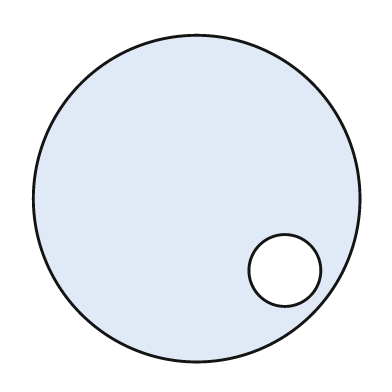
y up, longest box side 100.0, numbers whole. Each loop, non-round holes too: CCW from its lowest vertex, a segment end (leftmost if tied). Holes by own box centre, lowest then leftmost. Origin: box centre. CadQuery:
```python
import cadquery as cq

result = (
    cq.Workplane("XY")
    .moveTo(0.0, 0.0)
    .circle(50.0)
    .moveTo(27.0, -22.0)
    .circle(11.0)
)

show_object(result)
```